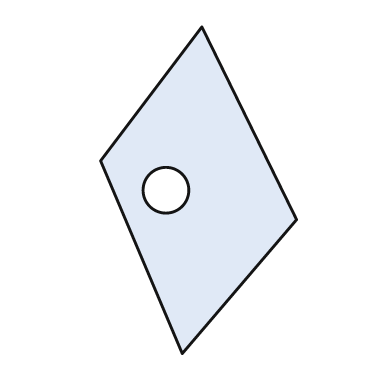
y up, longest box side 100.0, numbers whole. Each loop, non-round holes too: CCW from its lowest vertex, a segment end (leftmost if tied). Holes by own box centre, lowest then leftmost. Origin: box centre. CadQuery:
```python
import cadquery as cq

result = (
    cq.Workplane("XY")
    .moveTo(-5.0, -50.0)
    .lineTo(30.0, -9.0)
    .lineTo(1.0, 50.0)
    .lineTo(-30.0, 9.0)
    .close()
    .moveTo(-10.0, 0.0)
    .circle(7.0)
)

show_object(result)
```